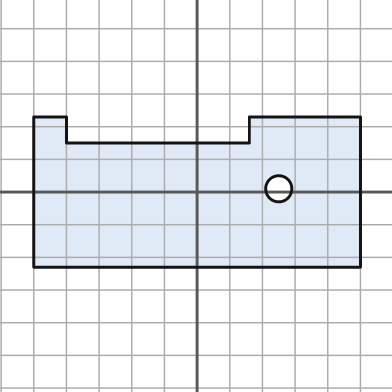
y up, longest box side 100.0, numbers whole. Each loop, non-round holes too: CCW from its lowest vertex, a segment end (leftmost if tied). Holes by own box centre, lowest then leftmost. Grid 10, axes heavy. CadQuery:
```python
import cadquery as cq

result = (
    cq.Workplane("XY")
    .moveTo(-50.0, -23.0)
    .lineTo(50.0, -23.0)
    .lineTo(50.0, 23.0)
    .lineTo(16.0, 23.0)
    .lineTo(16.0, 15.0)
    .lineTo(-40.0, 15.0)
    .lineTo(-40.0, 23.0)
    .lineTo(-50.0, 23.0)
    .close()
    .moveTo(25.0, 1.0)
    .circle(4.0)
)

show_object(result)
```